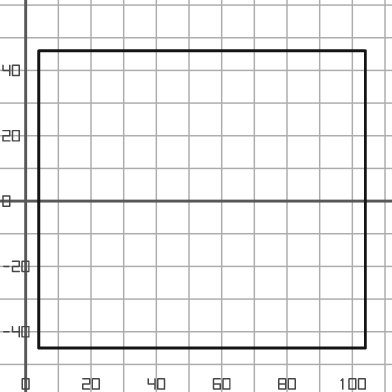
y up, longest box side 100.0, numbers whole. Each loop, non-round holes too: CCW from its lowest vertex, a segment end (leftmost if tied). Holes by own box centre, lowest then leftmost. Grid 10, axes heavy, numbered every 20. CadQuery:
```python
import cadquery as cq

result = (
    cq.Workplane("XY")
    .moveTo(4.0, -45.0)
    .lineTo(104.0, -45.0)
    .lineTo(104.0, 46.0)
    .lineTo(4.0, 46.0)
    .close()
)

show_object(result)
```